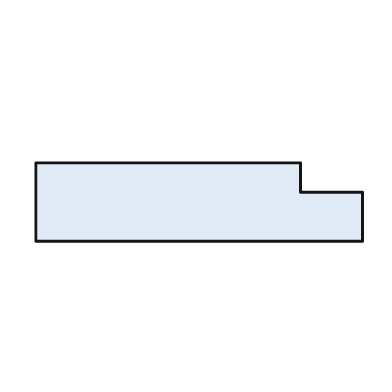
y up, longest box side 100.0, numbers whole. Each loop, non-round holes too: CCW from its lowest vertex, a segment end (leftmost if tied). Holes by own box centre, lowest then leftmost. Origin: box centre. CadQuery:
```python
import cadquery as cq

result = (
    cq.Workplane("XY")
    .moveTo(-50.0, -12.0)
    .lineTo(50.0, -12.0)
    .lineTo(50.0, 3.0)
    .lineTo(31.0, 3.0)
    .lineTo(31.0, 12.0)
    .lineTo(-50.0, 12.0)
    .close()
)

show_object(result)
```